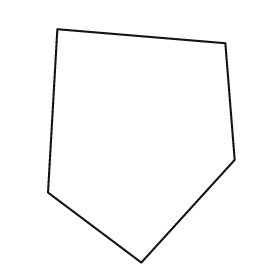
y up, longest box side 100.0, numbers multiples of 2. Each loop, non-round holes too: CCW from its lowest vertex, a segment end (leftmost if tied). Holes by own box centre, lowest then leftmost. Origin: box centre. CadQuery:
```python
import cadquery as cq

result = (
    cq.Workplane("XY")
    .moveTo(0.0, -50.0)
    .lineTo(40.0, -6.0)
    .lineTo(36.0, 44.0)
    .lineTo(-36.0, 50.0)
    .lineTo(-40.0, -20.0)
    .close()
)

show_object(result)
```